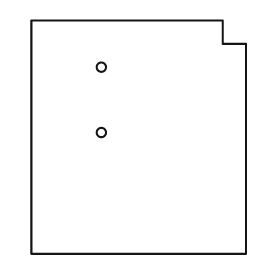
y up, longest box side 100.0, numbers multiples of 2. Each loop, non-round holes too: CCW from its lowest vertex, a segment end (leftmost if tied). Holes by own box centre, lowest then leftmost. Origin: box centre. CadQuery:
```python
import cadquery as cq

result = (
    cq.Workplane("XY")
    .moveTo(-46.0, -50.0)
    .lineTo(46.0, -50.0)
    .lineTo(46.0, 40.0)
    .lineTo(36.0, 40.0)
    .lineTo(36.0, 50.0)
    .lineTo(-46.0, 50.0)
    .close()
    .moveTo(-16.0, 2.0)
    .circle(2.0)
    .moveTo(-16.0, 30.0)
    .circle(2.0)
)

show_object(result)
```